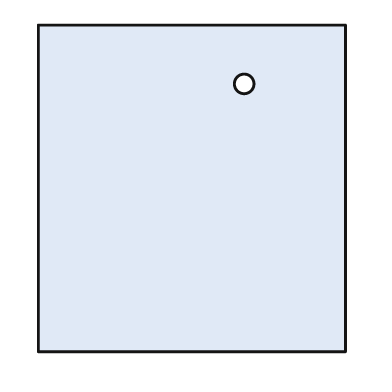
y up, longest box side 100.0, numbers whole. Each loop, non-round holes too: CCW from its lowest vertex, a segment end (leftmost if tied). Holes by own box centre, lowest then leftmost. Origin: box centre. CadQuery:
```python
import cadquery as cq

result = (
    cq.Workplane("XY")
    .moveTo(-47.0, -50.0)
    .lineTo(47.0, -50.0)
    .lineTo(47.0, 50.0)
    .lineTo(-47.0, 50.0)
    .close()
    .moveTo(16.0, 32.0)
    .circle(3.0)
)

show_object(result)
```